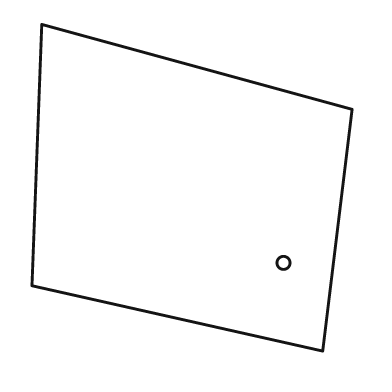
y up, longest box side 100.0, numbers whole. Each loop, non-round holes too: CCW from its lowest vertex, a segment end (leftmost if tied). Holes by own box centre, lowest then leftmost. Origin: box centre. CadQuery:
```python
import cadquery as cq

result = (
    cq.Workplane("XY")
    .moveTo(40.0, -50.0)
    .lineTo(49.0, 24.0)
    .lineTo(-46.0, 50.0)
    .lineTo(-49.0, -30.0)
    .close()
    .moveTo(28.0, -23.0)
    .circle(2.0)
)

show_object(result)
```